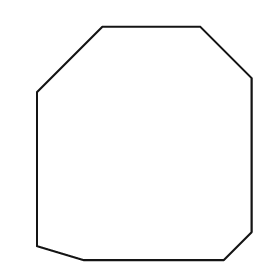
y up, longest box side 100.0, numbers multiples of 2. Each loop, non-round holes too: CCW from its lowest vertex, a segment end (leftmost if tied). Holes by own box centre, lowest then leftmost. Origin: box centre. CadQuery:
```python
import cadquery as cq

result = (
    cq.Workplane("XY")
    .moveTo(-26.0, -50.0)
    .lineTo(34.0, -50.0)
    .lineTo(46.0, -38.0)
    .lineTo(46.0, 28.0)
    .lineTo(24.0, 50.0)
    .lineTo(-18.0, 50.0)
    .lineTo(-46.0, 22.0)
    .lineTo(-46.0, -44.0)
    .close()
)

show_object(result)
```